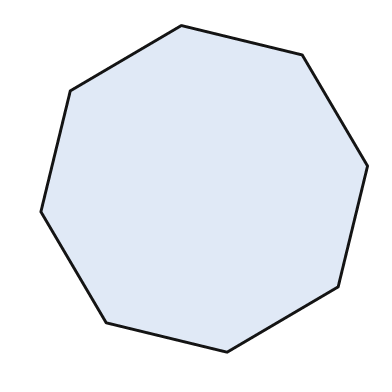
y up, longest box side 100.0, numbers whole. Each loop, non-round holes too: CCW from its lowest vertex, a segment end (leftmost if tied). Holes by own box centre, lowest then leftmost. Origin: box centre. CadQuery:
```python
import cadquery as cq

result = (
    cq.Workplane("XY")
    .moveTo(7.0, -50.0)
    .lineTo(41.0, -30.0)
    .lineTo(50.0, 7.0)
    .lineTo(30.0, 41.0)
    .lineTo(-7.0, 50.0)
    .lineTo(-41.0, 30.0)
    .lineTo(-50.0, -7.0)
    .lineTo(-30.0, -41.0)
    .close()
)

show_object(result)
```